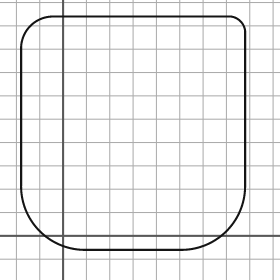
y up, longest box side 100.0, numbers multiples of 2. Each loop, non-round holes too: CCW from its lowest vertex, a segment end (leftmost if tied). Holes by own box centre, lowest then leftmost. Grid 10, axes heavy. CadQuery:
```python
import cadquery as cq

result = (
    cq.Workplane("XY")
    .moveTo(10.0, -6.0)
    .lineTo(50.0, -6.0)
    .threePointArc((70.0, 2.0), (78.0, 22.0))
    .lineTo(78.0, 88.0)
    .threePointArc((76.0, 92.0), (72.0, 94.0))
    .lineTo(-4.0, 94.0)
    .threePointArc((-14.0, 90.0), (-18.0, 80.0))
    .lineTo(-18.0, 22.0)
    .threePointArc((-10.0, 2.0), (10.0, -6.0))
    .close()
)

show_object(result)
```